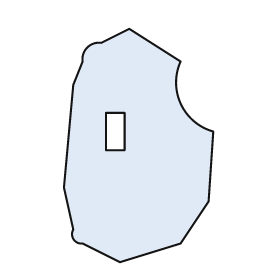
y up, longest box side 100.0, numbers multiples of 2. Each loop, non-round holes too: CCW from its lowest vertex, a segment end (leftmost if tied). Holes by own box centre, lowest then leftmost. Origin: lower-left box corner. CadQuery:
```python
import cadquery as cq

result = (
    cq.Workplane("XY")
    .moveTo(24.0, 0.0)
    .lineTo(50.0, 8.0)
    .lineTo(62.0, 26.0)
    .lineTo(64.0, 56.0)
    .threePointArc((50.0, 68.0), (50.0, 86.0))
    .lineTo(28.0, 100.0)
    .lineTo(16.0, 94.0)
    .threePointArc((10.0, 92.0), (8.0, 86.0))
    .lineTo(4.0, 76.0)
    .lineTo(0.0, 32.0)
    .lineTo(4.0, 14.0)
    .threePointArc((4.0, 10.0), (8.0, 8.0))
    .close()
    .moveTo(18.0, 48.0)
    .lineTo(26.0, 48.0)
    .lineTo(26.0, 64.0)
    .lineTo(18.0, 64.0)
    .close()
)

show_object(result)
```